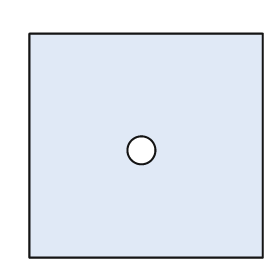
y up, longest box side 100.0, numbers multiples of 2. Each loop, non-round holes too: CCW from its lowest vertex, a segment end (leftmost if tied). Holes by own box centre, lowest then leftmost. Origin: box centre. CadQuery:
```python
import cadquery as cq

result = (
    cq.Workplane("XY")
    .moveTo(-50.0, -48.0)
    .lineTo(50.0, -48.0)
    .lineTo(50.0, 48.0)
    .lineTo(-50.0, 48.0)
    .close()
    .moveTo(-2.0, -2.0)
    .circle(6.0)
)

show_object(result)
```